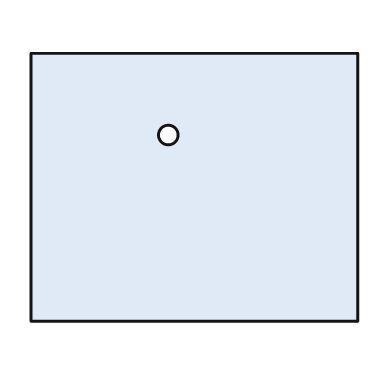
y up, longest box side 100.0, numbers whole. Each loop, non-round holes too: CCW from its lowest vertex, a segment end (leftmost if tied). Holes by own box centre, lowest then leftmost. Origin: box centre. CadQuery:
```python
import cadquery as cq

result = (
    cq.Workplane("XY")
    .moveTo(-50.0, -41.0)
    .lineTo(50.0, -41.0)
    .lineTo(50.0, 41.0)
    .lineTo(-50.0, 41.0)
    .close()
    .moveTo(-8.0, 16.0)
    .circle(3.0)
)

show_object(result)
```